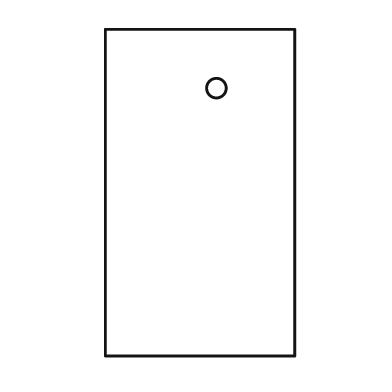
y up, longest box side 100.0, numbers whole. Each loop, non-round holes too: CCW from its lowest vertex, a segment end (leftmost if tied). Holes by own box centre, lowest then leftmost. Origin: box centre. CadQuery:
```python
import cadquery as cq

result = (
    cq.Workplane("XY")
    .moveTo(-29.0, -50.0)
    .lineTo(29.0, -50.0)
    .lineTo(29.0, 50.0)
    .lineTo(-29.0, 50.0)
    .close()
    .moveTo(5.0, 32.0)
    .circle(3.0)
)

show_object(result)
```